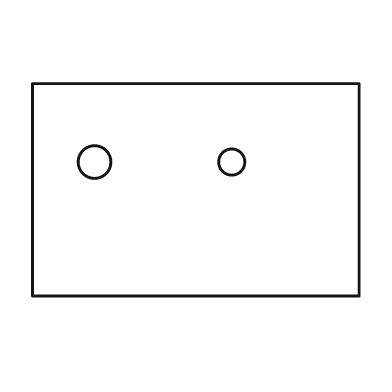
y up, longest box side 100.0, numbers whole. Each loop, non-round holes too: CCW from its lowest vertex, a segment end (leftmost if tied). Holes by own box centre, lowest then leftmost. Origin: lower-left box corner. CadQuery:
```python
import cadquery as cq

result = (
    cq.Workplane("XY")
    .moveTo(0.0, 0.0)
    .lineTo(100.0, 0.0)
    .lineTo(100.0, 65.0)
    .lineTo(0.0, 65.0)
    .close()
    .moveTo(19.0, 41.0)
    .circle(5.0)
    .moveTo(61.0, 41.0)
    .circle(4.0)
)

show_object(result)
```